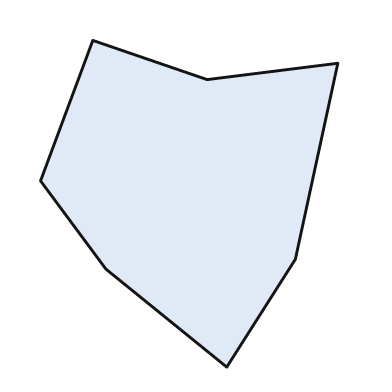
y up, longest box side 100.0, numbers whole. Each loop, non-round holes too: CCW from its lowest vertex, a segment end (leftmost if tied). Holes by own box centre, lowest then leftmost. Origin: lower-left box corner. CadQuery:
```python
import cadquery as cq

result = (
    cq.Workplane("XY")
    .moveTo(57.0, 0.0)
    .lineTo(78.0, 33.0)
    .lineTo(91.0, 93.0)
    .lineTo(51.0, 88.0)
    .lineTo(16.0, 100.0)
    .lineTo(0.0, 57.0)
    .lineTo(20.0, 30.0)
    .close()
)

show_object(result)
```